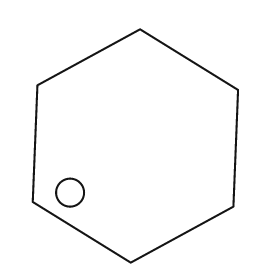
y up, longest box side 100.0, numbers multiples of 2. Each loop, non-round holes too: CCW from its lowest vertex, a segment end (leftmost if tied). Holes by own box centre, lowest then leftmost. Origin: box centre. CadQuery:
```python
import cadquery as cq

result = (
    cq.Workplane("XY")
    .moveTo(-2.0, -50.0)
    .lineTo(42.0, -26.0)
    .lineTo(44.0, 24.0)
    .lineTo(2.0, 50.0)
    .lineTo(-42.0, 26.0)
    .lineTo(-44.0, -24.0)
    .close()
    .moveTo(-28.0, -20.0)
    .circle(6.0)
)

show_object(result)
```